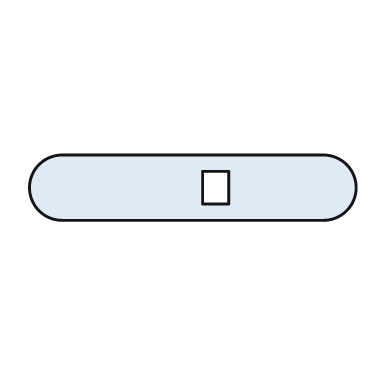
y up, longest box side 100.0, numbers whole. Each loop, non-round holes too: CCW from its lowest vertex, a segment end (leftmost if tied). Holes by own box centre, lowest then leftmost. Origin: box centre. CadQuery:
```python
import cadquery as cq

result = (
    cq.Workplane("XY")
    .moveTo(-40.0, -10.0)
    .lineTo(40.0, -10.0)
    .threePointArc((50.0, 0.0), (40.0, 10.0))
    .lineTo(-40.0, 10.0)
    .threePointArc((-50.0, 0.0), (-40.0, -10.0))
    .close()
    .moveTo(3.0, -5.0)
    .lineTo(11.0, -5.0)
    .lineTo(11.0, 5.0)
    .lineTo(3.0, 5.0)
    .close()
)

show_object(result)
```